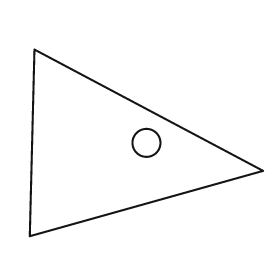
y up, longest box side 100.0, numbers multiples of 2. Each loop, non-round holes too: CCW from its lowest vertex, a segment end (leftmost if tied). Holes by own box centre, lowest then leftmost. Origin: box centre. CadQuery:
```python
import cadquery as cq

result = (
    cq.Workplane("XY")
    .moveTo(-50.0, -40.0)
    .lineTo(50.0, -12.0)
    .lineTo(-48.0, 40.0)
    .close()
    .moveTo(0.0, 0.0)
    .circle(6.0)
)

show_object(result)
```